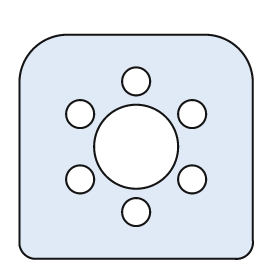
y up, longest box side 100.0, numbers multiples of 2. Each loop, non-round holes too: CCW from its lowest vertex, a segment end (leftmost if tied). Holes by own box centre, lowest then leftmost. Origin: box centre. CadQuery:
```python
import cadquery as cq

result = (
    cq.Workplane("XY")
    .moveTo(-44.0, -48.0)
    .lineTo(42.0, -48.0)
    .threePointArc((48.0, -46.0), (50.0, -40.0))
    .lineTo(50.0, 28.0)
    .threePointArc((44.0, 42.0), (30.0, 48.0))
    .lineTo(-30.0, 48.0)
    .threePointArc((-44.0, 42.0), (-50.0, 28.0))
    .lineTo(-50.0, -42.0)
    .threePointArc((-48.0, -46.0), (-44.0, -48.0))
    .close()
    .moveTo(0.0, -28.0)
    .circle(6.0)
    .moveTo(-24.0, -14.0)
    .circle(6.0)
    .moveTo(24.0, -14.0)
    .circle(6.0)
    .moveTo(0.0, 0.0)
    .circle(18.0)
    .moveTo(-24.0, 14.0)
    .circle(6.0)
    .moveTo(24.0, 14.0)
    .circle(6.0)
    .moveTo(0.0, 28.0)
    .circle(6.0)
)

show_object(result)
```